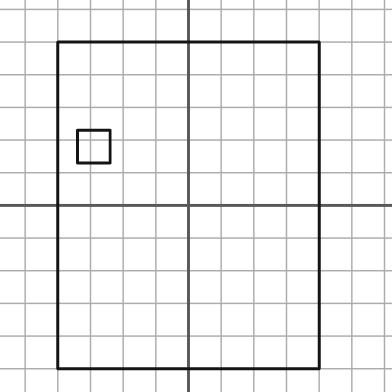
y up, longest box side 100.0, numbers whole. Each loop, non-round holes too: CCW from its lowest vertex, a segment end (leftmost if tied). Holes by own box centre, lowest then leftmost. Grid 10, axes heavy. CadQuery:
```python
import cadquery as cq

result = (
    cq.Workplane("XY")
    .moveTo(-40.0, -50.0)
    .lineTo(40.0, -50.0)
    .lineTo(40.0, 50.0)
    .lineTo(-40.0, 50.0)
    .close()
    .moveTo(-34.0, 13.0)
    .lineTo(-24.0, 13.0)
    .lineTo(-24.0, 23.0)
    .lineTo(-34.0, 23.0)
    .close()
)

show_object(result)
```